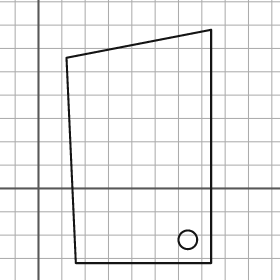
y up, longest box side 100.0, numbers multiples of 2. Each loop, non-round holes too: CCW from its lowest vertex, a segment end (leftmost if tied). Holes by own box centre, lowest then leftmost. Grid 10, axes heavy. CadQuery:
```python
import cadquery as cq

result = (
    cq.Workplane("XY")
    .moveTo(16.0, -32.0)
    .lineTo(74.0, -32.0)
    .lineTo(74.0, 68.0)
    .lineTo(12.0, 56.0)
    .close()
    .moveTo(64.0, -22.0)
    .circle(4.0)
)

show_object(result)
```